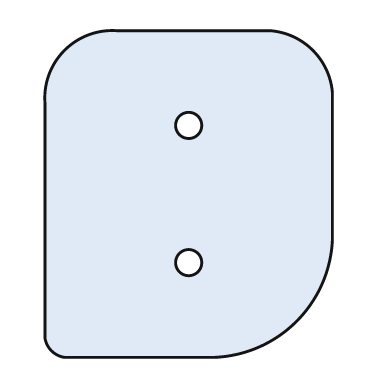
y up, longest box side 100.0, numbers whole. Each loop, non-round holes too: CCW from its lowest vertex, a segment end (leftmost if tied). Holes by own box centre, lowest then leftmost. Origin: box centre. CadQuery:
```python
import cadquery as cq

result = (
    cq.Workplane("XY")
    .moveTo(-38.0, -50.0)
    .lineTo(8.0, -50.0)
    .threePointArc((33.0, -39.0), (44.0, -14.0))
    .lineTo(44.0, 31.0)
    .threePointArc((38.0, 44.0), (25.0, 50.0))
    .lineTo(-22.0, 50.0)
    .threePointArc((-38.0, 44.0), (-44.0, 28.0))
    .lineTo(-44.0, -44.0)
    .threePointArc((-42.0, -48.0), (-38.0, -50.0))
    .close()
    .moveTo(0.0, -21.0)
    .circle(4.0)
    .moveTo(0.0, 21.0)
    .circle(4.0)
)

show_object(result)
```